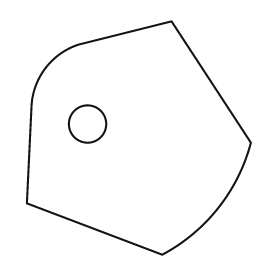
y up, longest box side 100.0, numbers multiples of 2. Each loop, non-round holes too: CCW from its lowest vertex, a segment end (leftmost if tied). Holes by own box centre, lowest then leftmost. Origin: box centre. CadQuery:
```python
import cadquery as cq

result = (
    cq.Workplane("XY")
    .moveTo(10.0, -50.0)
    .threePointArc((34.0, -30.0), (48.0, -2.0))
    .lineTo(14.0, 50.0)
    .lineTo(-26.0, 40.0)
    .threePointArc((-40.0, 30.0), (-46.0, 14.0))
    .lineTo(-48.0, -28.0)
    .close()
    .moveTo(-22.0, 6.0)
    .circle(8.0)
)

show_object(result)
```